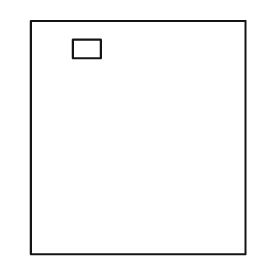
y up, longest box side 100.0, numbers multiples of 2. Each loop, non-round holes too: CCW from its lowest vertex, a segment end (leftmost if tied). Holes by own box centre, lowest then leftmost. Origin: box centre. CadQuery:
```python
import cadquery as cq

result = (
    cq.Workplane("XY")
    .moveTo(-46.0, -50.0)
    .lineTo(46.0, -50.0)
    .lineTo(46.0, 50.0)
    .lineTo(-46.0, 50.0)
    .close()
    .moveTo(-28.0, 34.0)
    .lineTo(-16.0, 34.0)
    .lineTo(-16.0, 42.0)
    .lineTo(-28.0, 42.0)
    .close()
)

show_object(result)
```